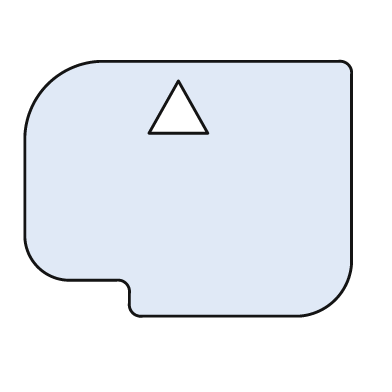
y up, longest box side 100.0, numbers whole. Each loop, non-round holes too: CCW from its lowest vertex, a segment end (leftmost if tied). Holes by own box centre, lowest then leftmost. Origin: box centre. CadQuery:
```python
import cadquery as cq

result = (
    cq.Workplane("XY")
    .moveTo(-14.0, -39.0)
    .lineTo(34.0, -39.0)
    .threePointArc((45.0, -34.0), (50.0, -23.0))
    .lineTo(50.0, 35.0)
    .threePointArc((49.0, 38.0), (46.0, 39.0))
    .lineTo(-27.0, 39.0)
    .threePointArc((-43.0, 32.0), (-50.0, 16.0))
    .lineTo(-50.0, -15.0)
    .threePointArc((-46.0, -24.0), (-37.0, -28.0))
    .lineTo(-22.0, -28.0)
    .threePointArc((-19.0, -29.0), (-18.0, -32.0))
    .lineTo(-18.0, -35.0)
    .threePointArc((-17.0, -38.0), (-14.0, -39.0))
    .close()
    .moveTo(-12.0, 17.0)
    .lineTo(6.0, 17.0)
    .lineTo(-3.0, 33.0)
    .close()
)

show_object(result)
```